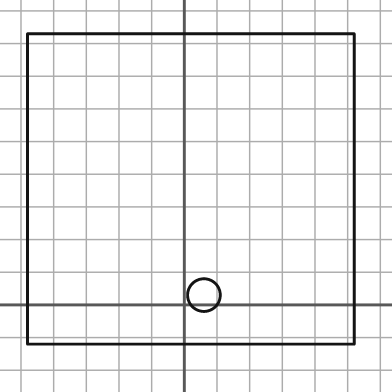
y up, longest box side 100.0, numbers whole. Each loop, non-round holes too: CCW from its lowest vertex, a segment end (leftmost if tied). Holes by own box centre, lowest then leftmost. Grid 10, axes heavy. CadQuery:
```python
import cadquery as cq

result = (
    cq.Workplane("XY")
    .moveTo(-48.0, -12.0)
    .lineTo(52.0, -12.0)
    .lineTo(52.0, 83.0)
    .lineTo(-48.0, 83.0)
    .close()
    .moveTo(6.0, 3.0)
    .circle(5.0)
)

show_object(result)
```